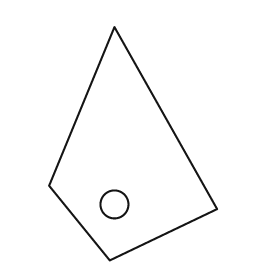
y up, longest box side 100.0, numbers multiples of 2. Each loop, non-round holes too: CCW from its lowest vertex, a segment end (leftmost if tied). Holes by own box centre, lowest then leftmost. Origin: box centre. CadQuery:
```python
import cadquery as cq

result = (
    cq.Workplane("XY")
    .moveTo(-10.0, -50.0)
    .lineTo(36.0, -28.0)
    .lineTo(-8.0, 50.0)
    .lineTo(-36.0, -18.0)
    .close()
    .moveTo(-8.0, -26.0)
    .circle(6.0)
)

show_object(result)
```